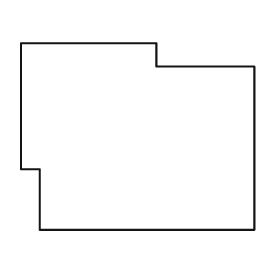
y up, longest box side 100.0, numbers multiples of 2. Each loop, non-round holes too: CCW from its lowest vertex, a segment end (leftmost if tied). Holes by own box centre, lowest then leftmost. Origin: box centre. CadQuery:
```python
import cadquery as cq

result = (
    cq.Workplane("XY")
    .moveTo(-42.0, -40.0)
    .lineTo(50.0, -40.0)
    .lineTo(50.0, 30.0)
    .lineTo(8.0, 30.0)
    .lineTo(8.0, 40.0)
    .lineTo(-50.0, 40.0)
    .lineTo(-50.0, -14.0)
    .lineTo(-42.0, -14.0)
    .close()
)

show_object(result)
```